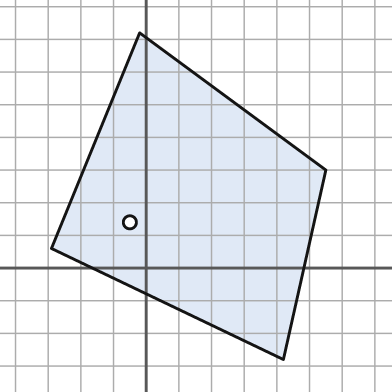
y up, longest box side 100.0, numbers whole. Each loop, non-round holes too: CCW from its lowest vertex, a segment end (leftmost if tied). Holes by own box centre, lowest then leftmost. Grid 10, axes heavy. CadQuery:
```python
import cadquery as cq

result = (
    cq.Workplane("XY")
    .moveTo(42.0, -28.0)
    .lineTo(55.0, 30.0)
    .lineTo(-2.0, 72.0)
    .lineTo(-29.0, 6.0)
    .close()
    .moveTo(-5.0, 14.0)
    .circle(2.0)
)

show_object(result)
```